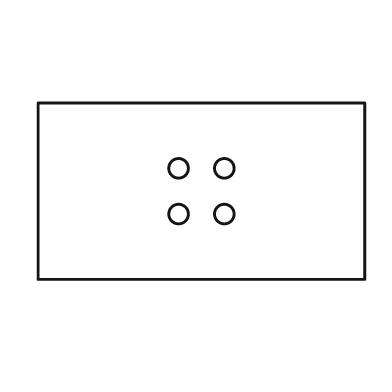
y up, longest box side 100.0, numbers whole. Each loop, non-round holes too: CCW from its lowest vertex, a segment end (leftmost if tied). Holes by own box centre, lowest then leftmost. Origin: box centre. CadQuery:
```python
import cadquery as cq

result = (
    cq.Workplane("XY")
    .moveTo(-50.0, -27.0)
    .lineTo(50.0, -27.0)
    .lineTo(50.0, 27.0)
    .lineTo(-50.0, 27.0)
    .close()
    .moveTo(-7.0, -7.0)
    .circle(3.0)
    .moveTo(7.0, -7.0)
    .circle(3.0)
    .moveTo(-7.0, 7.0)
    .circle(3.0)
    .moveTo(7.0, 7.0)
    .circle(3.0)
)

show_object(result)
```